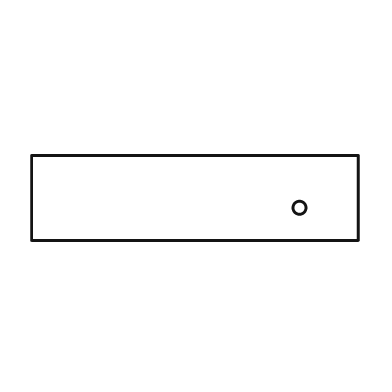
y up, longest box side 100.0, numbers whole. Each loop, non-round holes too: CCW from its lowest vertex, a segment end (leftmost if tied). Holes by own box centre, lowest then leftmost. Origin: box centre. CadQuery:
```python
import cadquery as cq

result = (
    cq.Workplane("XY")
    .moveTo(-50.0, -13.0)
    .lineTo(50.0, -13.0)
    .lineTo(50.0, 13.0)
    .lineTo(-50.0, 13.0)
    .close()
    .moveTo(32.0, -3.0)
    .circle(2.0)
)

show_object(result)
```